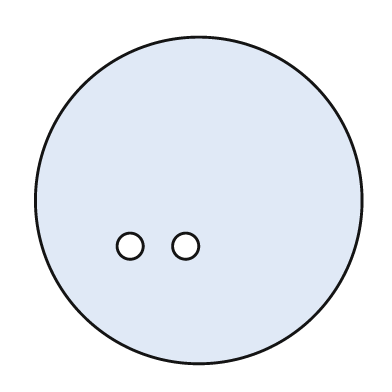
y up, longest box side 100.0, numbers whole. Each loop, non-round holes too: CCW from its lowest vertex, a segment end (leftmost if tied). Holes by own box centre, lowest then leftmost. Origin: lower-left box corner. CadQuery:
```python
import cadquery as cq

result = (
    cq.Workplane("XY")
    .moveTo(50.0, 50.0)
    .circle(50.0)
    .moveTo(29.0, 36.0)
    .circle(4.0)
    .moveTo(46.0, 36.0)
    .circle(4.0)
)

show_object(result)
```